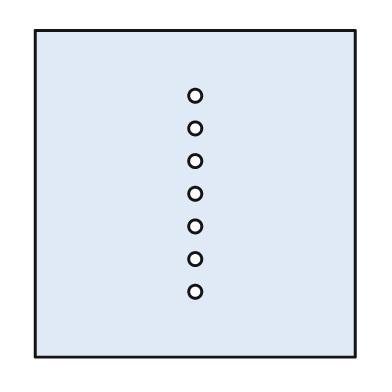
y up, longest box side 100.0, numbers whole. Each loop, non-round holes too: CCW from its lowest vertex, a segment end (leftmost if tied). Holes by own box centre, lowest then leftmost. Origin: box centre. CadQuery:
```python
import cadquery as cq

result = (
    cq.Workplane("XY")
    .moveTo(-49.0, -50.0)
    .lineTo(49.0, -50.0)
    .lineTo(49.0, 50.0)
    .lineTo(-49.0, 50.0)
    .close()
    .moveTo(0.0, -30.0)
    .circle(2.0)
    .moveTo(0.0, -20.0)
    .circle(2.0)
    .moveTo(0.0, -10.0)
    .circle(2.0)
    .moveTo(0.0, 0.0)
    .circle(2.0)
    .moveTo(0.0, 10.0)
    .circle(2.0)
    .moveTo(0.0, 20.0)
    .circle(2.0)
    .moveTo(0.0, 30.0)
    .circle(2.0)
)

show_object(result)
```